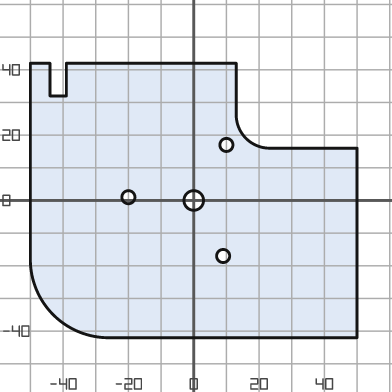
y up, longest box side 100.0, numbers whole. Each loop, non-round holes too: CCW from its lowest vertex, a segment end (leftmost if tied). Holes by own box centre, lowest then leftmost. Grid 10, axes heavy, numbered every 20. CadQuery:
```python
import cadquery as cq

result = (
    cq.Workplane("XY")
    .moveTo(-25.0, -42.0)
    .lineTo(50.0, -42.0)
    .lineTo(50.0, 16.0)
    .lineTo(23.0, 16.0)
    .threePointArc((16.0, 19.0), (13.0, 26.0))
    .lineTo(13.0, 42.0)
    .lineTo(-39.0, 42.0)
    .lineTo(-39.0, 32.0)
    .lineTo(-44.0, 32.0)
    .lineTo(-44.0, 42.0)
    .lineTo(-50.0, 42.0)
    .lineTo(-50.0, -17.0)
    .threePointArc((-43.0, -35.0), (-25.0, -42.0))
    .close()
    .moveTo(9.0, -17.0)
    .circle(2.0)
    .moveTo(0.0, 0.0)
    .circle(3.0)
    .moveTo(-20.0, 1.0)
    .circle(2.0)
    .moveTo(10.0, 17.0)
    .circle(2.0)
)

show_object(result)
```